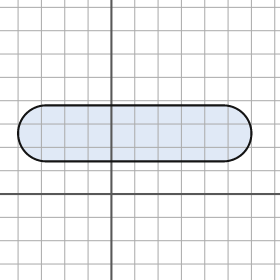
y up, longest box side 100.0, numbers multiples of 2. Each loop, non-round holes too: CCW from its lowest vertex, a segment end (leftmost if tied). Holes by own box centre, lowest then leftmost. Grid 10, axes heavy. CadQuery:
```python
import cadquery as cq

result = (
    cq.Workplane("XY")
    .moveTo(-28.0, 14.0)
    .lineTo(48.0, 14.0)
    .threePointArc((60.0, 26.0), (48.0, 38.0))
    .lineTo(-28.0, 38.0)
    .threePointArc((-40.0, 26.0), (-28.0, 14.0))
    .close()
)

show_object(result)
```